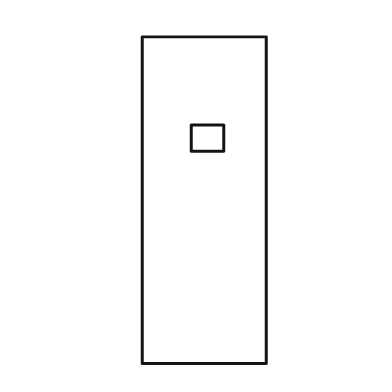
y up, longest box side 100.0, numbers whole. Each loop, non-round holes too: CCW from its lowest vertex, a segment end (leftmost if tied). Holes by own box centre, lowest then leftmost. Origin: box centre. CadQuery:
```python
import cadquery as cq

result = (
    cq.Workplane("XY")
    .moveTo(-19.0, -50.0)
    .lineTo(19.0, -50.0)
    .lineTo(19.0, 50.0)
    .lineTo(-19.0, 50.0)
    .close()
    .moveTo(-4.0, 15.0)
    .lineTo(6.0, 15.0)
    .lineTo(6.0, 23.0)
    .lineTo(-4.0, 23.0)
    .close()
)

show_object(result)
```